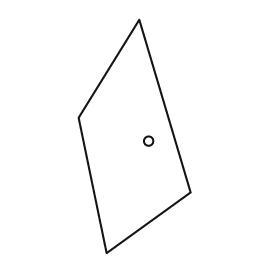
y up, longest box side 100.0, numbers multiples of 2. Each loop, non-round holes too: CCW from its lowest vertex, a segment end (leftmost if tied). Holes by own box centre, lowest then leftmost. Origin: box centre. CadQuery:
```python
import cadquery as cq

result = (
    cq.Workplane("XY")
    .moveTo(-12.0, -50.0)
    .lineTo(24.0, -24.0)
    .lineTo(2.0, 50.0)
    .lineTo(-24.0, 8.0)
    .close()
    .moveTo(6.0, -2.0)
    .circle(2.0)
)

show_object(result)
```